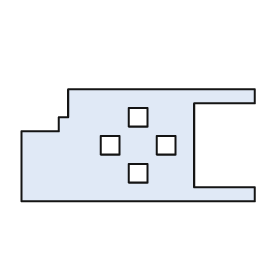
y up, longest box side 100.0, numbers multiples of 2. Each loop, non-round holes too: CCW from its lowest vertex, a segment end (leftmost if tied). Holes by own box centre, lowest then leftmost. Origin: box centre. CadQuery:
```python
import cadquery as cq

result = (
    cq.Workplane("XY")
    .moveTo(-50.0, -24.0)
    .lineTo(50.0, -24.0)
    .lineTo(50.0, -18.0)
    .lineTo(24.0, -18.0)
    .lineTo(24.0, 18.0)
    .lineTo(50.0, 18.0)
    .lineTo(50.0, 24.0)
    .lineTo(-30.0, 24.0)
    .lineTo(-30.0, 12.0)
    .lineTo(-34.0, 12.0)
    .lineTo(-34.0, 6.0)
    .lineTo(-50.0, 6.0)
    .close()
    .moveTo(-4.0, -16.0)
    .lineTo(4.0, -16.0)
    .lineTo(4.0, -8.0)
    .lineTo(-4.0, -8.0)
    .close()
    .moveTo(-16.0, -4.0)
    .lineTo(-8.0, -4.0)
    .lineTo(-8.0, 4.0)
    .lineTo(-16.0, 4.0)
    .close()
    .moveTo(8.0, -4.0)
    .lineTo(16.0, -4.0)
    .lineTo(16.0, 4.0)
    .lineTo(8.0, 4.0)
    .close()
    .moveTo(-4.0, 8.0)
    .lineTo(4.0, 8.0)
    .lineTo(4.0, 16.0)
    .lineTo(-4.0, 16.0)
    .close()
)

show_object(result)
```